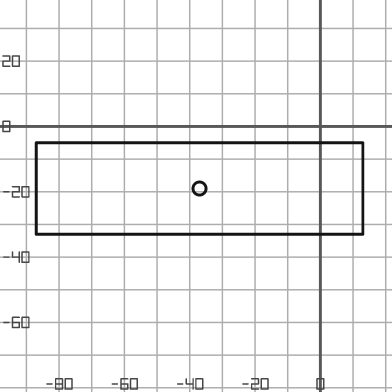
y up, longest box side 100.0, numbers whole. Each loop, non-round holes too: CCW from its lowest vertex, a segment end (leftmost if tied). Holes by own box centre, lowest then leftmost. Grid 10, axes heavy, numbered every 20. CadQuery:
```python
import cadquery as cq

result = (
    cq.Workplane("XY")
    .moveTo(-87.0, -33.0)
    .lineTo(13.0, -33.0)
    .lineTo(13.0, -5.0)
    .lineTo(-87.0, -5.0)
    .close()
    .moveTo(-37.0, -19.0)
    .circle(2.0)
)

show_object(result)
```